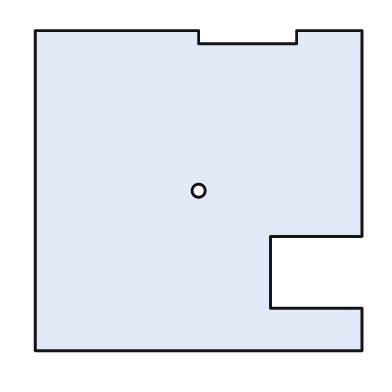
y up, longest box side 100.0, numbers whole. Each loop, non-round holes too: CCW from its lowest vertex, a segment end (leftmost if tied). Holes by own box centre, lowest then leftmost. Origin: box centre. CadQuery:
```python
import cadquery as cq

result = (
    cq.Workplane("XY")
    .moveTo(-50.0, -49.0)
    .lineTo(50.0, -49.0)
    .lineTo(50.0, -36.0)
    .lineTo(22.0, -36.0)
    .lineTo(22.0, -14.0)
    .lineTo(50.0, -14.0)
    .lineTo(50.0, 49.0)
    .lineTo(30.0, 49.0)
    .lineTo(30.0, 45.0)
    .lineTo(0.0, 45.0)
    .lineTo(0.0, 49.0)
    .lineTo(-50.0, 49.0)
    .close()
    .moveTo(0.0, 0.0)
    .circle(2.0)
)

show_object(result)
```